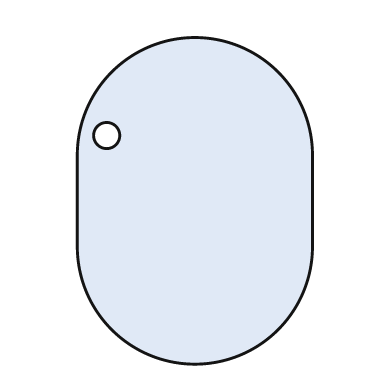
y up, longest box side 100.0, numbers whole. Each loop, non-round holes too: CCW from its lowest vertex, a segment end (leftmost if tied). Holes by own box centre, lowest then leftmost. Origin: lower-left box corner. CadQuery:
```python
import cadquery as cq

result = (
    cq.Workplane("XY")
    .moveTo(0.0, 36.0)
    .threePointArc((36.0, 0.0), (72.0, 36.0))
    .lineTo(72.0, 64.0)
    .threePointArc((36.0, 100.0), (0.0, 64.0))
    .close()
    .moveTo(9.0, 70.0)
    .circle(4.0)
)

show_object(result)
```